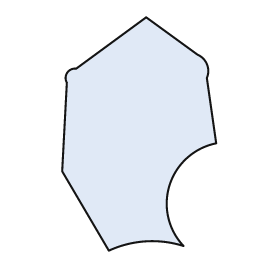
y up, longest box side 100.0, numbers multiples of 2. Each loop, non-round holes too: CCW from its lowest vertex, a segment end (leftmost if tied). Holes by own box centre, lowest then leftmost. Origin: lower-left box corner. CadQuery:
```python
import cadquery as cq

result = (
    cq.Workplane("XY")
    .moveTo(20.0, 0.0)
    .threePointArc((36.0, 4.0), (52.0, 2.0))
    .threePointArc((46.0, 28.0), (66.0, 46.0))
    .lineTo(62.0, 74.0)
    .threePointArc((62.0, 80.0), (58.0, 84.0))
    .lineTo(36.0, 100.0)
    .lineTo(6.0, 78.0)
    .threePointArc((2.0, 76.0), (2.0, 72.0))
    .lineTo(0.0, 34.0)
    .close()
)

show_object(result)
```